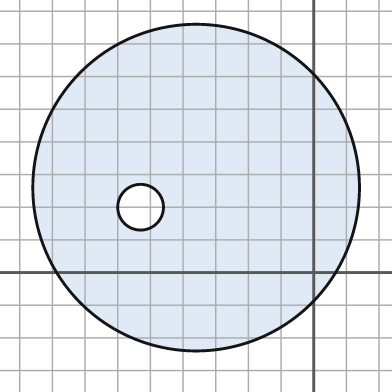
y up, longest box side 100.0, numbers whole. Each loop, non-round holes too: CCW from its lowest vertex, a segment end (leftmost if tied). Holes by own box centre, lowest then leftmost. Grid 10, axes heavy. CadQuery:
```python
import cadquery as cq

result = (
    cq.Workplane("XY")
    .moveTo(-36.0, 26.0)
    .circle(50.0)
    .moveTo(-53.0, 20.0)
    .circle(7.0)
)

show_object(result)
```